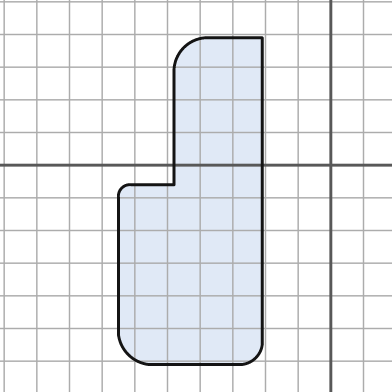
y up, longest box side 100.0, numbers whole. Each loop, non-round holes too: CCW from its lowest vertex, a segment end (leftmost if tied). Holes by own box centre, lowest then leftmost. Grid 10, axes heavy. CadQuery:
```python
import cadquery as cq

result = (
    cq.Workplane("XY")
    .moveTo(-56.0, -61.0)
    .lineTo(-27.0, -61.0)
    .threePointArc((-23.0, -59.0), (-21.0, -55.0))
    .lineTo(-21.0, 39.0)
    .lineTo(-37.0, 39.0)
    .threePointArc((-45.0, 36.0), (-48.0, 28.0))
    .lineTo(-48.0, -6.0)
    .lineTo(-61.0, -6.0)
    .threePointArc((-64.0, -7.0), (-65.0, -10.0))
    .lineTo(-65.0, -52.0)
    .threePointArc((-62.0, -58.0), (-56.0, -61.0))
    .close()
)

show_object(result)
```